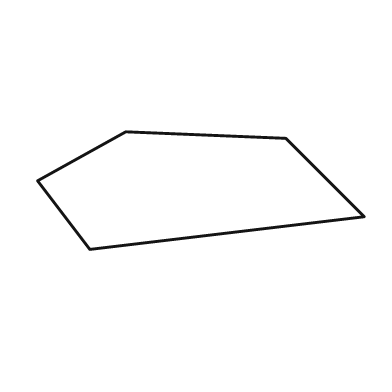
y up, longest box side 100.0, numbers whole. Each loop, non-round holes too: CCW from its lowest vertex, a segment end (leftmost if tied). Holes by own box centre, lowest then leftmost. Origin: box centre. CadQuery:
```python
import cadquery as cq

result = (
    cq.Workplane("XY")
    .moveTo(-34.0, -18.0)
    .lineTo(50.0, -8.0)
    .lineTo(26.0, 16.0)
    .lineTo(-23.0, 18.0)
    .lineTo(-50.0, 3.0)
    .close()
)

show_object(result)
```